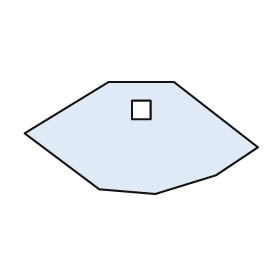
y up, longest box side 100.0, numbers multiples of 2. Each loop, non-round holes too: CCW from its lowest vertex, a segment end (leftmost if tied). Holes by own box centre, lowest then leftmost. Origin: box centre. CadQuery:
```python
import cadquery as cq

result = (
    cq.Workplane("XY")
    .moveTo(6.0, -24.0)
    .lineTo(32.0, -16.0)
    .lineTo(50.0, -4.0)
    .lineTo(14.0, 24.0)
    .lineTo(-14.0, 24.0)
    .lineTo(-50.0, 2.0)
    .lineTo(-18.0, -22.0)
    .close()
    .moveTo(-4.0, 8.0)
    .lineTo(4.0, 8.0)
    .lineTo(4.0, 16.0)
    .lineTo(-4.0, 16.0)
    .close()
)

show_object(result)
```